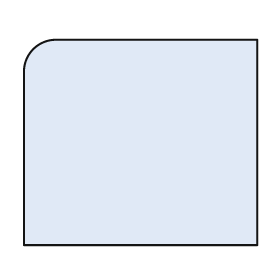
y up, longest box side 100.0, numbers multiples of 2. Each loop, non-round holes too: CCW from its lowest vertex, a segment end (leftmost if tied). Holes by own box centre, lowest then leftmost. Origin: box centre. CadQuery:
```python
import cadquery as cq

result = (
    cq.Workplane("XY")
    .moveTo(-50.0, -44.0)
    .lineTo(50.0, -44.0)
    .lineTo(50.0, 44.0)
    .lineTo(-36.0, 44.0)
    .threePointArc((-46.0, 40.0), (-50.0, 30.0))
    .close()
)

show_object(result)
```